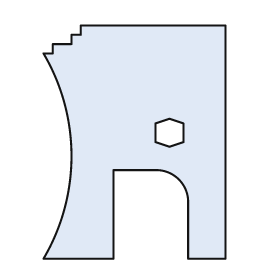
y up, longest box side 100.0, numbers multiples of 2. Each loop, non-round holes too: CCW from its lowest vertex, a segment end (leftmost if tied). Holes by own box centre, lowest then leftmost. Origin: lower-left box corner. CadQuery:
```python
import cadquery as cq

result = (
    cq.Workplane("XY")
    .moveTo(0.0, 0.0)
    .lineTo(30.0, 0.0)
    .lineTo(30.0, 38.0)
    .lineTo(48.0, 38.0)
    .threePointArc((58.0, 34.0), (62.0, 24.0))
    .lineTo(62.0, 0.0)
    .lineTo(78.0, 0.0)
    .lineTo(78.0, 100.0)
    .lineTo(16.0, 100.0)
    .lineTo(16.0, 96.0)
    .lineTo(12.0, 96.0)
    .lineTo(12.0, 92.0)
    .lineTo(4.0, 92.0)
    .lineTo(4.0, 88.0)
    .lineTo(0.0, 88.0)
    .threePointArc((12.0, 44.0), (0.0, 0.0))
    .close()
    .moveTo(54.0, 48.0)
    .lineTo(60.0, 50.0)
    .lineTo(60.0, 58.0)
    .lineTo(54.0, 60.0)
    .lineTo(48.0, 58.0)
    .lineTo(48.0, 50.0)
    .close()
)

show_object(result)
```